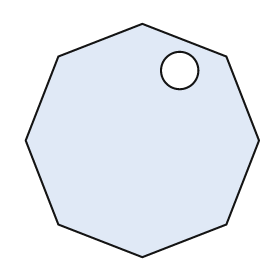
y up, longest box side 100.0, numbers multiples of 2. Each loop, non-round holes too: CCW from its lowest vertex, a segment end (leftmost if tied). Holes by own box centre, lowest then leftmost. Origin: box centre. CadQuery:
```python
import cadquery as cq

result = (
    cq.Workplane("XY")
    .moveTo(0.0, -50.0)
    .lineTo(36.0, -36.0)
    .lineTo(50.0, 0.0)
    .lineTo(36.0, 36.0)
    .lineTo(0.0, 50.0)
    .lineTo(-36.0, 36.0)
    .lineTo(-50.0, 0.0)
    .lineTo(-36.0, -36.0)
    .close()
    .moveTo(16.0, 30.0)
    .circle(8.0)
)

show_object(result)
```